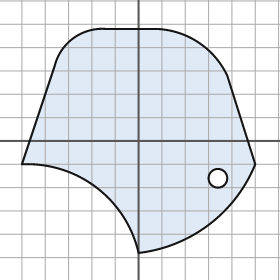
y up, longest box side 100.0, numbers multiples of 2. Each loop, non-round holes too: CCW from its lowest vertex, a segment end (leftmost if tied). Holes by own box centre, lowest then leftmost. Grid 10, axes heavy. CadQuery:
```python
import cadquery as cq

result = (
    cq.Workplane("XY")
    .moveTo(0.0, -48.0)
    .threePointArc((30.0, -36.0), (50.0, -10.0))
    .lineTo(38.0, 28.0)
    .threePointArc((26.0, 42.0), (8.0, 48.0))
    .lineTo(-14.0, 48.0)
    .threePointArc((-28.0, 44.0), (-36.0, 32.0))
    .lineTo(-50.0, -10.0)
    .threePointArc((-18.0, -20.0), (0.0, -48.0))
    .close()
    .moveTo(34.0, -16.0)
    .circle(4.0)
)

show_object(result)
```